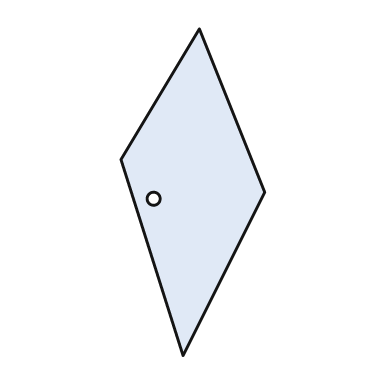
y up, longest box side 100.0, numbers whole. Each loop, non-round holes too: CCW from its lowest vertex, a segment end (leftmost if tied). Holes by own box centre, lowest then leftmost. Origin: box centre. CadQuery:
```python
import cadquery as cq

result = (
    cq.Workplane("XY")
    .moveTo(-3.0, -50.0)
    .lineTo(22.0, 0.0)
    .lineTo(2.0, 50.0)
    .lineTo(-22.0, 10.0)
    .close()
    .moveTo(-12.0, -2.0)
    .circle(2.0)
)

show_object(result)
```